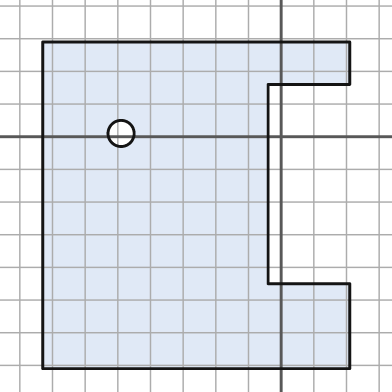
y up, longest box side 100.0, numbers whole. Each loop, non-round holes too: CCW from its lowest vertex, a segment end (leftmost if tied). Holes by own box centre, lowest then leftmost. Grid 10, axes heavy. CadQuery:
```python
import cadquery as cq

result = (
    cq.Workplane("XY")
    .moveTo(-73.0, -71.0)
    .lineTo(21.0, -71.0)
    .lineTo(21.0, -45.0)
    .lineTo(-4.0, -45.0)
    .lineTo(-4.0, 16.0)
    .lineTo(21.0, 16.0)
    .lineTo(21.0, 29.0)
    .lineTo(-73.0, 29.0)
    .close()
    .moveTo(-49.0, 1.0)
    .circle(4.0)
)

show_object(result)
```